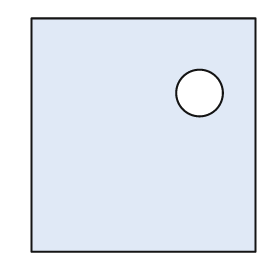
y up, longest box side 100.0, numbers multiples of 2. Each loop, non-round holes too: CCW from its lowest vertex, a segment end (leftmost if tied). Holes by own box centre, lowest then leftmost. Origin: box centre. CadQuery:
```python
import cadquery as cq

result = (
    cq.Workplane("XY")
    .moveTo(-48.0, -50.0)
    .lineTo(48.0, -50.0)
    .lineTo(48.0, 50.0)
    .lineTo(-48.0, 50.0)
    .close()
    .moveTo(24.0, 18.0)
    .circle(10.0)
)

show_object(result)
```